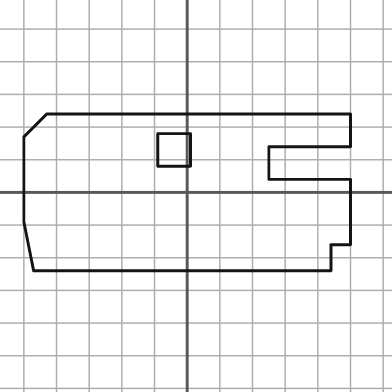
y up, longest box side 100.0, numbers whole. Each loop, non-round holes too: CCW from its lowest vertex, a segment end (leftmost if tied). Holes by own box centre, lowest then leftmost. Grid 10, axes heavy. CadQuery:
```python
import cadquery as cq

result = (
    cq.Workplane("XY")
    .moveTo(-47.0, -24.0)
    .lineTo(44.0, -24.0)
    .lineTo(44.0, -16.0)
    .lineTo(50.0, -16.0)
    .lineTo(50.0, 4.0)
    .lineTo(25.0, 4.0)
    .lineTo(25.0, 14.0)
    .lineTo(50.0, 14.0)
    .lineTo(50.0, 24.0)
    .lineTo(-43.0, 24.0)
    .lineTo(-50.0, 17.0)
    .lineTo(-50.0, -9.0)
    .close()
    .moveTo(-9.0, 8.0)
    .lineTo(1.0, 8.0)
    .lineTo(1.0, 18.0)
    .lineTo(-9.0, 18.0)
    .close()
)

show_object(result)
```